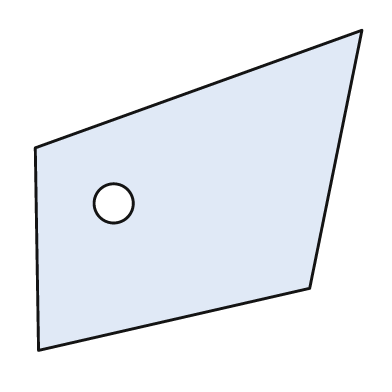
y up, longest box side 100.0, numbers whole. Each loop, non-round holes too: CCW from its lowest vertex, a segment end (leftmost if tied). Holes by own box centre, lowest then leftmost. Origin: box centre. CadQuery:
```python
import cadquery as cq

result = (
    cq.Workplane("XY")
    .moveTo(-49.0, -49.0)
    .lineTo(34.0, -30.0)
    .lineTo(50.0, 49.0)
    .lineTo(-50.0, 13.0)
    .close()
    .moveTo(-26.0, -4.0)
    .circle(6.0)
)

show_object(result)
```